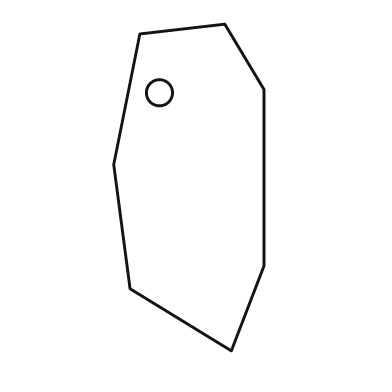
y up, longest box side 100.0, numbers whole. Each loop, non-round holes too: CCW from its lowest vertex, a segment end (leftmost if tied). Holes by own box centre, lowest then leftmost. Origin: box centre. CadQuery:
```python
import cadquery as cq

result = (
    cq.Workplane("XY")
    .moveTo(13.0, -50.0)
    .lineTo(23.0, -24.0)
    .lineTo(23.0, 30.0)
    .lineTo(11.0, 50.0)
    .lineTo(-15.0, 47.0)
    .lineTo(-23.0, 7.0)
    .lineTo(-18.0, -31.0)
    .close()
    .moveTo(-9.0, 29.0)
    .circle(4.0)
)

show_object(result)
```